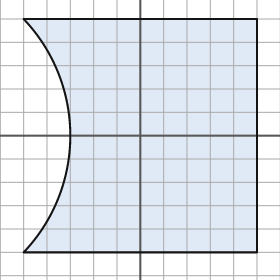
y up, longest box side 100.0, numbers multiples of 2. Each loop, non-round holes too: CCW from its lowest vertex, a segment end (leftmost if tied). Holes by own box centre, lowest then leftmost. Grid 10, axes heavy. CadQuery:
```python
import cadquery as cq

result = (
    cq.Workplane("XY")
    .moveTo(-50.0, -50.0)
    .lineTo(50.0, -50.0)
    .lineTo(50.0, 50.0)
    .lineTo(-50.0, 50.0)
    .threePointArc((-30.0, 0.0), (-50.0, -50.0))
    .close()
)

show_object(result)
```